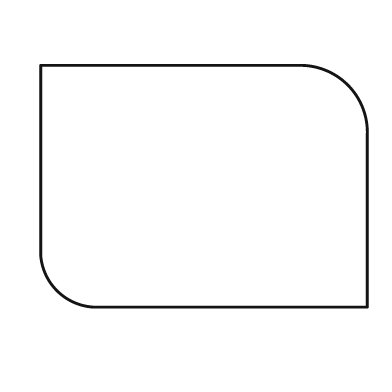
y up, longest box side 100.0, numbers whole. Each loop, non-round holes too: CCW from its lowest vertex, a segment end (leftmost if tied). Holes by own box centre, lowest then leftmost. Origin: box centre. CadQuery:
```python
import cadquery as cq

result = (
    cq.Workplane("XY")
    .moveTo(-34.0, -37.0)
    .lineTo(50.0, -37.0)
    .lineTo(50.0, 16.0)
    .threePointArc((44.0, 31.0), (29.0, 37.0))
    .lineTo(-50.0, 37.0)
    .lineTo(-50.0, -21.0)
    .threePointArc((-45.0, -32.0), (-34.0, -37.0))
    .close()
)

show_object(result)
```